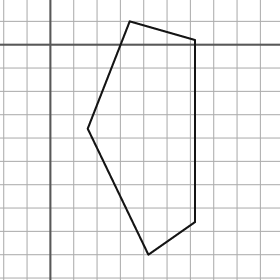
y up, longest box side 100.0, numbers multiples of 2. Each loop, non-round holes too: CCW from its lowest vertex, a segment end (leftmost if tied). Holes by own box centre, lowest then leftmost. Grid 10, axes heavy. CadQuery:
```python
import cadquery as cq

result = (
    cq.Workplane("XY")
    .moveTo(42.0, -90.0)
    .lineTo(62.0, -76.0)
    .lineTo(62.0, 2.0)
    .lineTo(34.0, 10.0)
    .lineTo(16.0, -36.0)
    .close()
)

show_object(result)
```